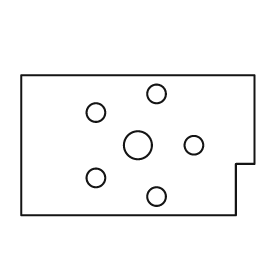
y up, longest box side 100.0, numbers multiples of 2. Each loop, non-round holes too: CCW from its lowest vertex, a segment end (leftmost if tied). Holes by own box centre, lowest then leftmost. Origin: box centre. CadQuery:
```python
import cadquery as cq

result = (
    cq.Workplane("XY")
    .moveTo(-50.0, -30.0)
    .lineTo(42.0, -30.0)
    .lineTo(42.0, -8.0)
    .lineTo(50.0, -8.0)
    .lineTo(50.0, 30.0)
    .lineTo(-50.0, 30.0)
    .close()
    .moveTo(8.0, -22.0)
    .circle(4.0)
    .moveTo(-18.0, -14.0)
    .circle(4.0)
    .moveTo(0.0, 0.0)
    .circle(6.0)
    .moveTo(24.0, 0.0)
    .circle(4.0)
    .moveTo(-18.0, 14.0)
    .circle(4.0)
    .moveTo(8.0, 22.0)
    .circle(4.0)
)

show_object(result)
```